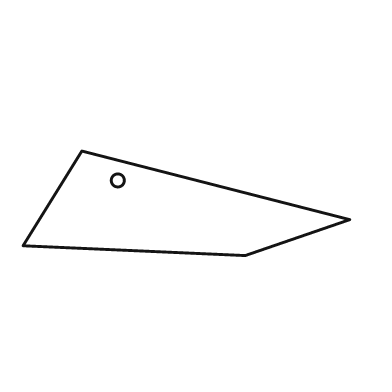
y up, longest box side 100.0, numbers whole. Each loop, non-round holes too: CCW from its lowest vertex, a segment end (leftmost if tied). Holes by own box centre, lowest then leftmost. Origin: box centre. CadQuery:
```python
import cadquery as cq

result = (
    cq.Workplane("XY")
    .moveTo(18.0, -16.0)
    .lineTo(50.0, -5.0)
    .lineTo(-32.0, 16.0)
    .lineTo(-50.0, -13.0)
    .close()
    .moveTo(-21.0, 7.0)
    .circle(2.0)
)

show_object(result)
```